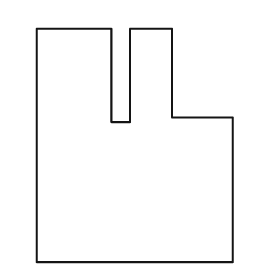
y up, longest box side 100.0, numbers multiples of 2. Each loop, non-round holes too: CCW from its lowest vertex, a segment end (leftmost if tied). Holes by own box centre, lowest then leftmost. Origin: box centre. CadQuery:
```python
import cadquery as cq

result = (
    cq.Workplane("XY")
    .moveTo(-42.0, -50.0)
    .lineTo(42.0, -50.0)
    .lineTo(42.0, 12.0)
    .lineTo(16.0, 12.0)
    .lineTo(16.0, 50.0)
    .lineTo(-2.0, 50.0)
    .lineTo(-2.0, 10.0)
    .lineTo(-10.0, 10.0)
    .lineTo(-10.0, 50.0)
    .lineTo(-42.0, 50.0)
    .close()
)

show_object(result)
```